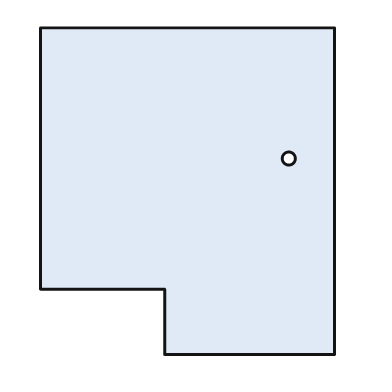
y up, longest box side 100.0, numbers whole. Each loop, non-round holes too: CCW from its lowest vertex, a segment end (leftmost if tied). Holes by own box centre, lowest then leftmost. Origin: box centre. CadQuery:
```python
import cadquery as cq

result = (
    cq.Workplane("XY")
    .moveTo(-7.0, -50.0)
    .lineTo(45.0, -50.0)
    .lineTo(45.0, 50.0)
    .lineTo(-45.0, 50.0)
    .lineTo(-45.0, -30.0)
    .lineTo(-7.0, -30.0)
    .close()
    .moveTo(31.0, 10.0)
    .circle(2.0)
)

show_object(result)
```